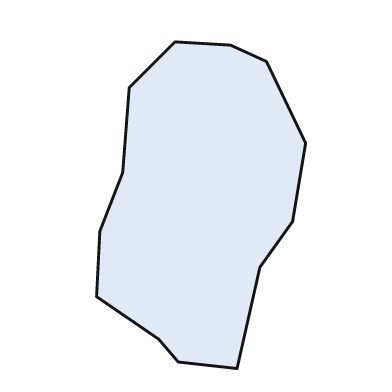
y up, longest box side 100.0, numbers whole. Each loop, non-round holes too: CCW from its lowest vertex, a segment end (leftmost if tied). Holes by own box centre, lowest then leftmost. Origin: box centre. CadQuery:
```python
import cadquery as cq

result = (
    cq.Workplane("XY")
    .moveTo(11.0, -50.0)
    .lineTo(18.0, -19.0)
    .lineTo(28.0, -5.0)
    .lineTo(32.0, 19.0)
    .lineTo(20.0, 44.0)
    .lineTo(9.0, 49.0)
    .lineTo(-8.0, 50.0)
    .lineTo(-22.0, 36.0)
    .lineTo(-24.0, 10.0)
    .lineTo(-31.0, -8.0)
    .lineTo(-32.0, -28.0)
    .lineTo(-13.0, -41.0)
    .lineTo(-7.0, -48.0)
    .close()
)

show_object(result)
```